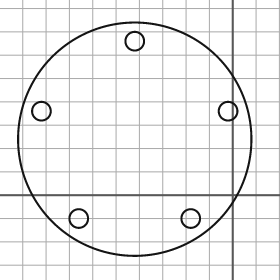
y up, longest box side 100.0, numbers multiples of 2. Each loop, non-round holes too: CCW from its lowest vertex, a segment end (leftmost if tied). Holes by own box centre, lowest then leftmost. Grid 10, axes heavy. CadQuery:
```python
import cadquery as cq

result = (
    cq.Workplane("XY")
    .moveTo(-42.0, 24.0)
    .circle(50.0)
    .moveTo(-66.0, -10.0)
    .circle(4.0)
    .moveTo(-18.0, -10.0)
    .circle(4.0)
    .moveTo(-82.0, 36.0)
    .circle(4.0)
    .moveTo(-2.0, 36.0)
    .circle(4.0)
    .moveTo(-42.0, 66.0)
    .circle(4.0)
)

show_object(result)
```